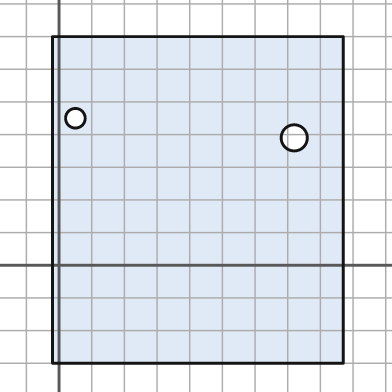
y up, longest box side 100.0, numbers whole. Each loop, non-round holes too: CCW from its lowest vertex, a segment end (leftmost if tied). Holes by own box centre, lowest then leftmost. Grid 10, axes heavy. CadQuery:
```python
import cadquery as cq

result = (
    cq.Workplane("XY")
    .moveTo(-2.0, -30.0)
    .lineTo(87.0, -30.0)
    .lineTo(87.0, 70.0)
    .lineTo(-2.0, 70.0)
    .close()
    .moveTo(72.0, 39.0)
    .circle(4.0)
    .moveTo(5.0, 45.0)
    .circle(3.0)
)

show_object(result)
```